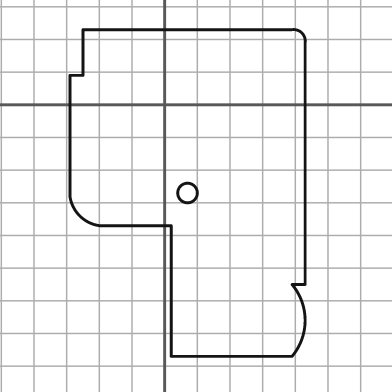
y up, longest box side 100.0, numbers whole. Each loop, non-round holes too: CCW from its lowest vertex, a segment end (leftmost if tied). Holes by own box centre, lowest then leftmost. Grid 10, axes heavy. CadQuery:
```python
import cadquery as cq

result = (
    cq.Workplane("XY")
    .moveTo(2.0, -77.0)
    .lineTo(39.0, -77.0)
    .threePointArc((43.0, -66.0), (39.0, -55.0))
    .lineTo(43.0, -55.0)
    .lineTo(43.0, 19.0)
    .threePointArc((42.0, 22.0), (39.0, 23.0))
    .lineTo(-25.0, 23.0)
    .lineTo(-25.0, 9.0)
    .lineTo(-29.0, 9.0)
    .lineTo(-29.0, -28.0)
    .threePointArc((-26.0, -34.0), (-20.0, -37.0))
    .lineTo(2.0, -37.0)
    .close()
    .moveTo(7.0, -27.0)
    .circle(3.0)
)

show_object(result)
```